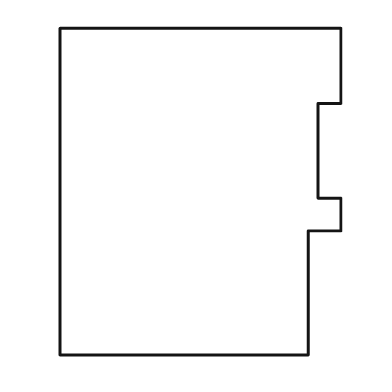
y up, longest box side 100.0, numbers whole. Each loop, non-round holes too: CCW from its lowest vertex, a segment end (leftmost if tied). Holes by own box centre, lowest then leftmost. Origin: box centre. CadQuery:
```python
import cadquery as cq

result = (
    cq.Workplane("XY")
    .moveTo(-43.0, -50.0)
    .lineTo(33.0, -50.0)
    .lineTo(33.0, -12.0)
    .lineTo(43.0, -12.0)
    .lineTo(43.0, -2.0)
    .lineTo(36.0, -2.0)
    .lineTo(36.0, 27.0)
    .lineTo(43.0, 27.0)
    .lineTo(43.0, 50.0)
    .lineTo(-43.0, 50.0)
    .close()
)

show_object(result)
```